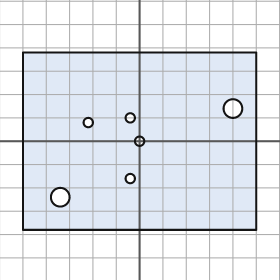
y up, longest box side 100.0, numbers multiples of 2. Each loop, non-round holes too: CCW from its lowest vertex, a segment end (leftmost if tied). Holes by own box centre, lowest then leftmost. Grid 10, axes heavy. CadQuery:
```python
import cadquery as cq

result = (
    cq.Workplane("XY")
    .moveTo(-50.0, -38.0)
    .lineTo(50.0, -38.0)
    .lineTo(50.0, 38.0)
    .lineTo(-50.0, 38.0)
    .close()
    .moveTo(-34.0, -24.0)
    .circle(4.0)
    .moveTo(-4.0, -16.0)
    .circle(2.0)
    .moveTo(0.0, 0.0)
    .circle(2.0)
    .moveTo(-22.0, 8.0)
    .circle(2.0)
    .moveTo(-4.0, 10.0)
    .circle(2.0)
    .moveTo(40.0, 14.0)
    .circle(4.0)
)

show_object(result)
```